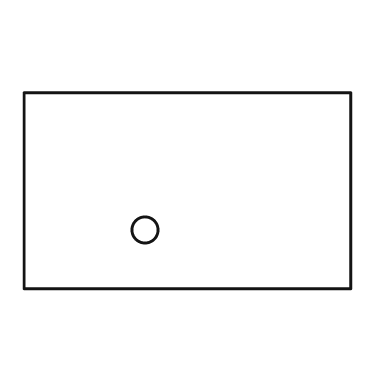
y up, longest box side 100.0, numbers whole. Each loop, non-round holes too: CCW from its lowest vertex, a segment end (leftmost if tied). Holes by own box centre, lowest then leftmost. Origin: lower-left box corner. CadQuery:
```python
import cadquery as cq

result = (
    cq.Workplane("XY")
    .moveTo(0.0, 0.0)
    .lineTo(100.0, 0.0)
    .lineTo(100.0, 60.0)
    .lineTo(0.0, 60.0)
    .close()
    .moveTo(37.0, 18.0)
    .circle(4.0)
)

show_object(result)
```